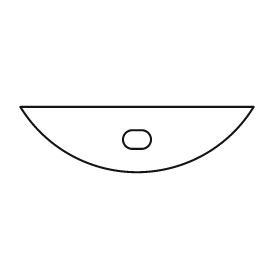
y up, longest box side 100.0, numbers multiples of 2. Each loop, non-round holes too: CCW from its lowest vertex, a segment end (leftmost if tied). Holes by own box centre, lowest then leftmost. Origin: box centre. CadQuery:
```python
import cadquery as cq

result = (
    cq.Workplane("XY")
    .moveTo(-50.0, 14.0)
    .threePointArc((0.0, -14.0), (50.0, 14.0))
    .close()
    .moveTo(-2.0, -4.0)
    .lineTo(2.0, -4.0)
    .threePointArc((6.0, 0.0), (2.0, 4.0))
    .lineTo(-2.0, 4.0)
    .threePointArc((-6.0, 0.0), (-2.0, -4.0))
    .close()
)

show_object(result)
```